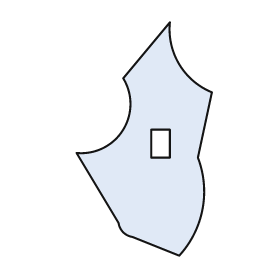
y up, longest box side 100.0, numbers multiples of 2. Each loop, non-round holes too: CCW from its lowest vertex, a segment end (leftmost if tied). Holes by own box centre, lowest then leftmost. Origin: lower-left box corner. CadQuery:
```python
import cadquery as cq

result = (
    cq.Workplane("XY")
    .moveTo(44.0, 0.0)
    .threePointArc((54.0, 20.0), (52.0, 42.0))
    .lineTo(58.0, 70.0)
    .threePointArc((44.0, 82.0), (40.0, 100.0))
    .lineTo(20.0, 76.0)
    .threePointArc((20.0, 54.0), (0.0, 44.0))
    .lineTo(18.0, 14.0)
    .threePointArc((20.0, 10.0), (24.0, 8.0))
    .close()
    .moveTo(32.0, 42.0)
    .lineTo(40.0, 42.0)
    .lineTo(40.0, 54.0)
    .lineTo(32.0, 54.0)
    .close()
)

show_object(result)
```